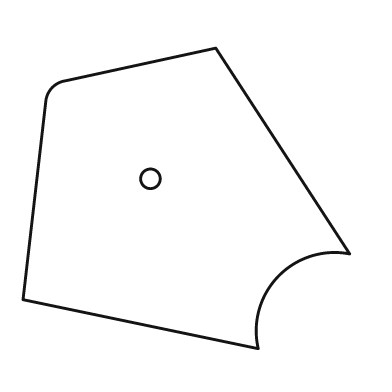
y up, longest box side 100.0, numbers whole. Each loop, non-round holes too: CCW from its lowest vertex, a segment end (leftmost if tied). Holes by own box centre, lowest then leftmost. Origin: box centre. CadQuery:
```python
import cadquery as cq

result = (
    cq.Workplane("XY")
    .moveTo(22.0, -46.0)
    .threePointArc((28.0, -24.0), (50.0, -17.0))
    .lineTo(9.0, 46.0)
    .lineTo(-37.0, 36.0)
    .threePointArc((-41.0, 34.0), (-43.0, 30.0))
    .lineTo(-50.0, -31.0)
    .close()
    .moveTo(-11.0, 6.0)
    .circle(3.0)
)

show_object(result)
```